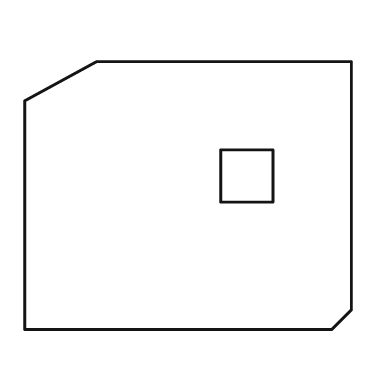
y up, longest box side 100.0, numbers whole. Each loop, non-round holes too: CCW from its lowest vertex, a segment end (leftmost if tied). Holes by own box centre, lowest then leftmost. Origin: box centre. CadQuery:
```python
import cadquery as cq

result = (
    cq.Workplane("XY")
    .moveTo(-50.0, -41.0)
    .lineTo(44.0, -41.0)
    .lineTo(50.0, -35.0)
    .lineTo(50.0, 41.0)
    .lineTo(-28.0, 41.0)
    .lineTo(-50.0, 29.0)
    .close()
    .moveTo(10.0, -2.0)
    .lineTo(26.0, -2.0)
    .lineTo(26.0, 14.0)
    .lineTo(10.0, 14.0)
    .close()
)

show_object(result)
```